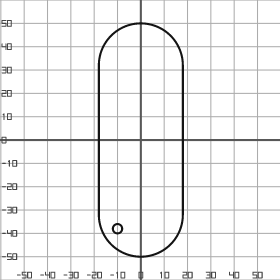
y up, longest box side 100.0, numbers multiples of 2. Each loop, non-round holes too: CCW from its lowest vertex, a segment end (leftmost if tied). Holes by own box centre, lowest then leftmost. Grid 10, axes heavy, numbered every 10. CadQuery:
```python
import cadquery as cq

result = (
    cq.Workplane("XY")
    .moveTo(-18.0, -32.0)
    .threePointArc((0.0, -50.0), (18.0, -32.0))
    .lineTo(18.0, 32.0)
    .threePointArc((0.0, 50.0), (-18.0, 32.0))
    .close()
    .moveTo(-10.0, -38.0)
    .circle(2.0)
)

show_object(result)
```